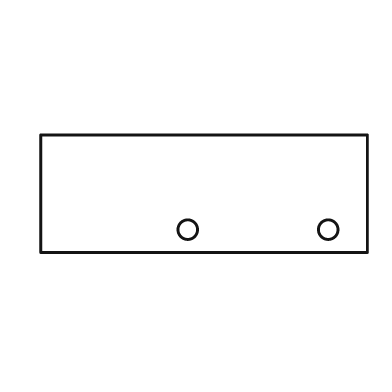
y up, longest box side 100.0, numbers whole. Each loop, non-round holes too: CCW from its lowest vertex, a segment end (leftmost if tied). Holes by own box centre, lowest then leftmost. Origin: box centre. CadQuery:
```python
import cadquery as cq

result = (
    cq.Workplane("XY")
    .moveTo(-50.0, -18.0)
    .lineTo(50.0, -18.0)
    .lineTo(50.0, 18.0)
    .lineTo(-50.0, 18.0)
    .close()
    .moveTo(-5.0, -11.0)
    .circle(3.0)
    .moveTo(38.0, -11.0)
    .circle(3.0)
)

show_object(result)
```